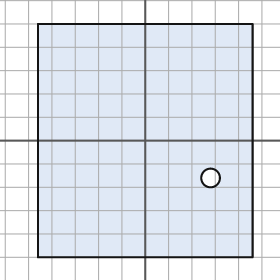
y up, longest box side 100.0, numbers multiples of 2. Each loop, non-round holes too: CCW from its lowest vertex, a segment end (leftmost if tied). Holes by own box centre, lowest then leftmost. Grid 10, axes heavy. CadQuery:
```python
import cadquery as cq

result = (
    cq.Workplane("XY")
    .moveTo(-46.0, -50.0)
    .lineTo(46.0, -50.0)
    .lineTo(46.0, 50.0)
    .lineTo(-46.0, 50.0)
    .close()
    .moveTo(28.0, -16.0)
    .circle(4.0)
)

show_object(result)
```